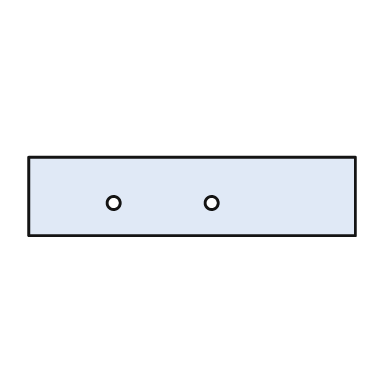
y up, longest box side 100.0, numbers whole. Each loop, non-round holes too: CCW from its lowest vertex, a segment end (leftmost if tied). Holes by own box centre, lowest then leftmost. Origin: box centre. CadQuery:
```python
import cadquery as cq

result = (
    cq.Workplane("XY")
    .moveTo(-50.0, -12.0)
    .lineTo(50.0, -12.0)
    .lineTo(50.0, 12.0)
    .lineTo(-50.0, 12.0)
    .close()
    .moveTo(-24.0, -2.0)
    .circle(2.0)
    .moveTo(6.0, -2.0)
    .circle(2.0)
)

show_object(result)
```